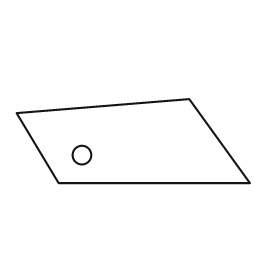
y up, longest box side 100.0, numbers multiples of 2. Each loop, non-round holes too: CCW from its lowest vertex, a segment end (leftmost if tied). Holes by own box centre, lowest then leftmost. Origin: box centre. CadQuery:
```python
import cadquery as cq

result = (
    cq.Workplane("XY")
    .moveTo(-32.0, -18.0)
    .lineTo(50.0, -18.0)
    .lineTo(24.0, 18.0)
    .lineTo(-50.0, 12.0)
    .close()
    .moveTo(-22.0, -6.0)
    .circle(4.0)
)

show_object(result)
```